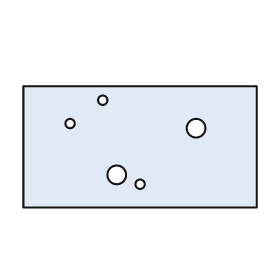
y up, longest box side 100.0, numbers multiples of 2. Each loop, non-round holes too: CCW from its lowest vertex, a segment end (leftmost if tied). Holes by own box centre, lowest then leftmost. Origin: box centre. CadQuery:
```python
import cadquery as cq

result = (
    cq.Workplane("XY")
    .moveTo(-50.0, -26.0)
    .lineTo(50.0, -26.0)
    .lineTo(50.0, 26.0)
    .lineTo(-50.0, 26.0)
    .close()
    .moveTo(0.0, -16.0)
    .circle(2.0)
    .moveTo(-10.0, -12.0)
    .circle(4.0)
    .moveTo(24.0, 8.0)
    .circle(4.0)
    .moveTo(-30.0, 10.0)
    .circle(2.0)
    .moveTo(-16.0, 20.0)
    .circle(2.0)
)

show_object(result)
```